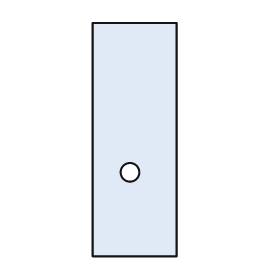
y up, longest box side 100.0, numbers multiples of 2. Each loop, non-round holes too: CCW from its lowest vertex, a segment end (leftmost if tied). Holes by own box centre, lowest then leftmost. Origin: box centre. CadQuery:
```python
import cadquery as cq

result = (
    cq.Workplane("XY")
    .moveTo(-18.0, -50.0)
    .lineTo(18.0, -50.0)
    .lineTo(18.0, 50.0)
    .lineTo(-18.0, 50.0)
    .close()
    .moveTo(-2.0, -14.0)
    .circle(4.0)
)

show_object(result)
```